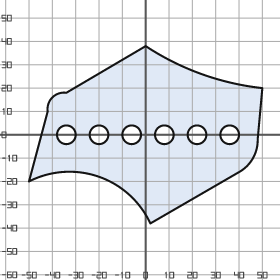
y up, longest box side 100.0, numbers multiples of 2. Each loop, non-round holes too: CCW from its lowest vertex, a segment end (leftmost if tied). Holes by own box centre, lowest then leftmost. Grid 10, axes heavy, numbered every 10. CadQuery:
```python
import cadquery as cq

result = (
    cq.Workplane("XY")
    .moveTo(2.0, -38.0)
    .lineTo(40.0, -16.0)
    .threePointArc((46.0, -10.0), (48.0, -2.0))
    .lineTo(50.0, 20.0)
    .threePointArc((24.0, 26.0), (0.0, 38.0))
    .lineTo(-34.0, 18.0)
    .threePointArc((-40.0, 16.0), (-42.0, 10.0))
    .lineTo(-50.0, -20.0)
    .threePointArc((-20.0, -18.0), (2.0, -38.0))
    .close()
    .moveTo(-34.0, 0.0)
    .circle(4.0)
    .moveTo(-20.0, 0.0)
    .circle(4.0)
    .moveTo(-6.0, 0.0)
    .circle(4.0)
    .moveTo(8.0, 0.0)
    .circle(4.0)
    .moveTo(22.0, 0.0)
    .circle(4.0)
    .moveTo(36.0, 0.0)
    .circle(4.0)
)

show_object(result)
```